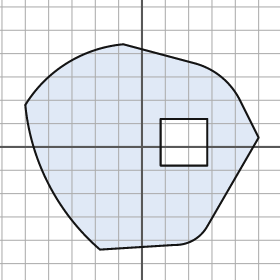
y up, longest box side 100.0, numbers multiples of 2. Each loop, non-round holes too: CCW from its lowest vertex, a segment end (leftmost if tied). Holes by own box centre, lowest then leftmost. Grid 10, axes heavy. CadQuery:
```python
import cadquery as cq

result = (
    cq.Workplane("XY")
    .moveTo(-18.0, -44.0)
    .lineTo(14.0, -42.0)
    .threePointArc((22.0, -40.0), (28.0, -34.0))
    .lineTo(50.0, 4.0)
    .lineTo(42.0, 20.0)
    .threePointArc((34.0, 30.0), (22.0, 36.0))
    .lineTo(-8.0, 44.0)
    .threePointArc((-32.0, 36.0), (-50.0, 18.0))
    .threePointArc((-40.0, -16.0), (-18.0, -44.0))
    .close()
    .moveTo(8.0, -8.0)
    .lineTo(28.0, -8.0)
    .lineTo(28.0, 12.0)
    .lineTo(8.0, 12.0)
    .close()
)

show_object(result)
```